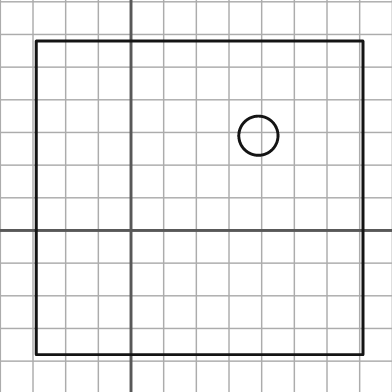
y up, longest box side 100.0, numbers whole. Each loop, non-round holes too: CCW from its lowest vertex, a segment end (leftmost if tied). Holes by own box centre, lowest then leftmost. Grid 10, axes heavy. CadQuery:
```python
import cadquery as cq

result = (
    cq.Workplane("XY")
    .moveTo(-29.0, -38.0)
    .lineTo(71.0, -38.0)
    .lineTo(71.0, 58.0)
    .lineTo(-29.0, 58.0)
    .close()
    .moveTo(39.0, 29.0)
    .circle(6.0)
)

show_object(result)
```